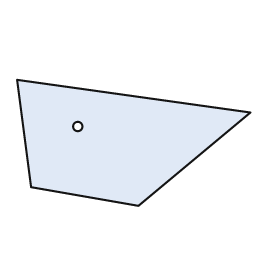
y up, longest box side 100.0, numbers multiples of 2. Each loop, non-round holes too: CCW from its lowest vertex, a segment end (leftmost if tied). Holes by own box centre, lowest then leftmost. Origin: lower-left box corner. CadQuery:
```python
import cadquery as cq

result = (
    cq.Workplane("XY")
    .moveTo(52.0, 0.0)
    .lineTo(100.0, 40.0)
    .lineTo(0.0, 54.0)
    .lineTo(6.0, 8.0)
    .close()
    .moveTo(26.0, 34.0)
    .circle(2.0)
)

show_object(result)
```